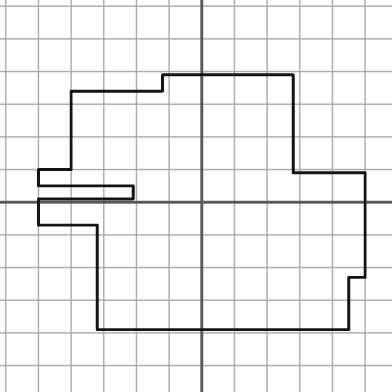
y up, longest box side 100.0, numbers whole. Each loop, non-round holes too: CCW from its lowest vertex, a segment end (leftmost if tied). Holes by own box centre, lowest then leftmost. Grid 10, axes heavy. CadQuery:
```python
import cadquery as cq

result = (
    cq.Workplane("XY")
    .moveTo(-32.0, -39.0)
    .lineTo(45.0, -39.0)
    .lineTo(45.0, -23.0)
    .lineTo(50.0, -23.0)
    .lineTo(50.0, 9.0)
    .lineTo(28.0, 9.0)
    .lineTo(28.0, 39.0)
    .lineTo(-12.0, 39.0)
    .lineTo(-12.0, 34.0)
    .lineTo(-40.0, 34.0)
    .lineTo(-40.0, 10.0)
    .lineTo(-50.0, 10.0)
    .lineTo(-50.0, 5.0)
    .lineTo(-21.0, 5.0)
    .lineTo(-21.0, 1.0)
    .lineTo(-50.0, 1.0)
    .lineTo(-50.0, -7.0)
    .lineTo(-32.0, -7.0)
    .close()
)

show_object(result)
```